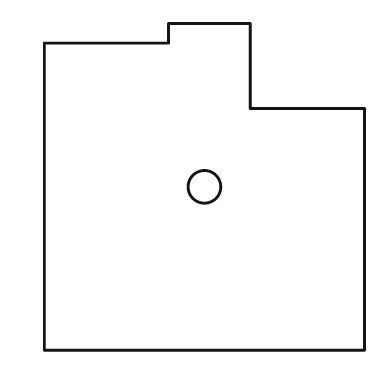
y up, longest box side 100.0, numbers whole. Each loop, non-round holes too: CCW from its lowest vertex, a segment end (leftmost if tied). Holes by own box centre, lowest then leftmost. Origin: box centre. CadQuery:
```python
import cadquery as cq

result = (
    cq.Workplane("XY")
    .moveTo(-49.0, -50.0)
    .lineTo(49.0, -50.0)
    .lineTo(49.0, 24.0)
    .lineTo(14.0, 24.0)
    .lineTo(14.0, 50.0)
    .lineTo(-11.0, 50.0)
    .lineTo(-11.0, 44.0)
    .lineTo(-49.0, 44.0)
    .close()
    .moveTo(0.0, 0.0)
    .circle(5.0)
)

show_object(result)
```